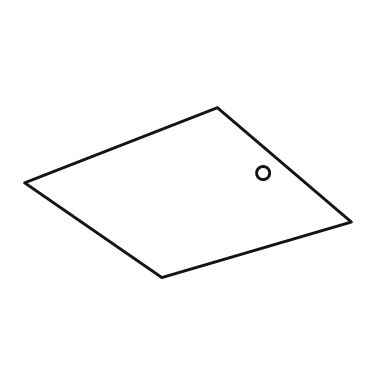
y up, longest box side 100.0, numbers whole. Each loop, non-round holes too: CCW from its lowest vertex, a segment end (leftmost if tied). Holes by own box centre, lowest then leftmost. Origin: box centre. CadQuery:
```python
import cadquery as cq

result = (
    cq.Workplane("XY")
    .moveTo(-8.0, -26.0)
    .lineTo(50.0, -9.0)
    .lineTo(9.0, 26.0)
    .lineTo(-50.0, 3.0)
    .close()
    .moveTo(23.0, 6.0)
    .circle(2.0)
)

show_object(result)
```